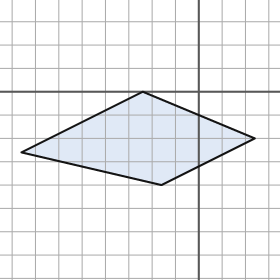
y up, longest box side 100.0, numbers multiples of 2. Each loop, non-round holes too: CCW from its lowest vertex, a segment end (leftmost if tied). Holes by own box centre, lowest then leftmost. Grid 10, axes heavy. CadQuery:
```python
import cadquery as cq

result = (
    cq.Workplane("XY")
    .moveTo(-16.0, -40.0)
    .lineTo(24.0, -20.0)
    .lineTo(-24.0, 0.0)
    .lineTo(-76.0, -26.0)
    .close()
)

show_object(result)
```